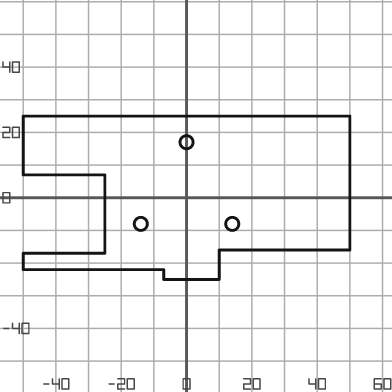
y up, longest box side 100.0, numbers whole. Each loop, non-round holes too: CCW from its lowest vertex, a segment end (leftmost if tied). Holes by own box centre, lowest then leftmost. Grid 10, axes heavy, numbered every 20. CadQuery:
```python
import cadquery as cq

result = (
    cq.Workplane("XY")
    .moveTo(-7.0, -25.0)
    .lineTo(10.0, -25.0)
    .lineTo(10.0, -16.0)
    .lineTo(50.0, -16.0)
    .lineTo(50.0, 25.0)
    .lineTo(-50.0, 25.0)
    .lineTo(-50.0, 7.0)
    .lineTo(-25.0, 7.0)
    .lineTo(-25.0, -17.0)
    .lineTo(-50.0, -17.0)
    .lineTo(-50.0, -22.0)
    .lineTo(-7.0, -22.0)
    .close()
    .moveTo(-14.0, -8.0)
    .circle(2.0)
    .moveTo(14.0, -8.0)
    .circle(2.0)
    .moveTo(0.0, 17.0)
    .circle(2.0)
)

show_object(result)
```